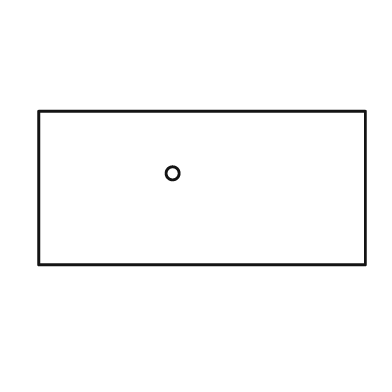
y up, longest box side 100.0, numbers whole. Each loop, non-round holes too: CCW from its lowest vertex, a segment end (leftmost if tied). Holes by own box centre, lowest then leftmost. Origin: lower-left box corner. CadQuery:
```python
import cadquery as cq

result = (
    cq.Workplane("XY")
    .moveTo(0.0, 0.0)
    .lineTo(100.0, 0.0)
    .lineTo(100.0, 47.0)
    .lineTo(0.0, 47.0)
    .close()
    .moveTo(41.0, 28.0)
    .circle(2.0)
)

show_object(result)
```